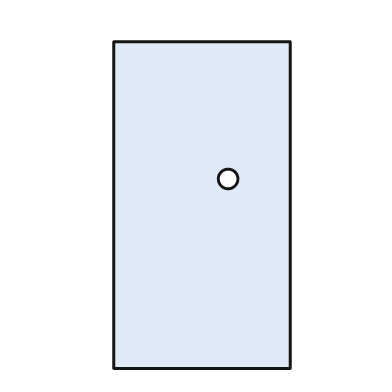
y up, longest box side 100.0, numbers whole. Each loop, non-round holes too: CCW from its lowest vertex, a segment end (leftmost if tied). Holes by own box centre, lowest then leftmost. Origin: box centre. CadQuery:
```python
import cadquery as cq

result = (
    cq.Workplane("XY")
    .moveTo(-27.0, -50.0)
    .lineTo(27.0, -50.0)
    .lineTo(27.0, 50.0)
    .lineTo(-27.0, 50.0)
    .close()
    .moveTo(8.0, 8.0)
    .circle(3.0)
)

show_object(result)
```